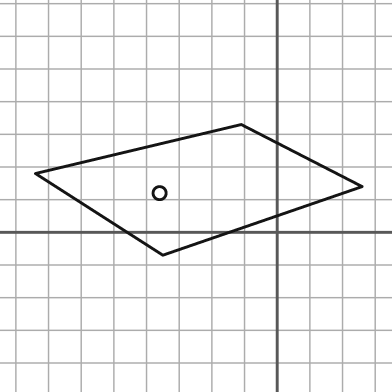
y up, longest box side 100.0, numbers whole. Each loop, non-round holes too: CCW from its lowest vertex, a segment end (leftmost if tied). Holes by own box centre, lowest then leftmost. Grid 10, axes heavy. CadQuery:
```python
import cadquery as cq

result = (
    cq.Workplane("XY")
    .moveTo(-35.0, -7.0)
    .lineTo(26.0, 14.0)
    .lineTo(-11.0, 33.0)
    .lineTo(-74.0, 18.0)
    .close()
    .moveTo(-36.0, 12.0)
    .circle(2.0)
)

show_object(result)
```